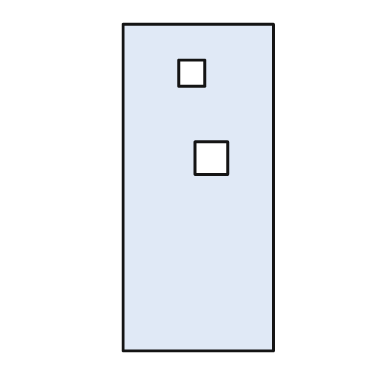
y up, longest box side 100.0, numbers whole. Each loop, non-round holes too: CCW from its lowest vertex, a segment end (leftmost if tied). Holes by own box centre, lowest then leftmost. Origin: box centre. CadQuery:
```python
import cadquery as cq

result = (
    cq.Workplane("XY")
    .moveTo(-23.0, -50.0)
    .lineTo(23.0, -50.0)
    .lineTo(23.0, 50.0)
    .lineTo(-23.0, 50.0)
    .close()
    .moveTo(-1.0, 4.0)
    .lineTo(9.0, 4.0)
    .lineTo(9.0, 14.0)
    .lineTo(-1.0, 14.0)
    .close()
    .moveTo(-6.0, 31.0)
    .lineTo(2.0, 31.0)
    .lineTo(2.0, 39.0)
    .lineTo(-6.0, 39.0)
    .close()
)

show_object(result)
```